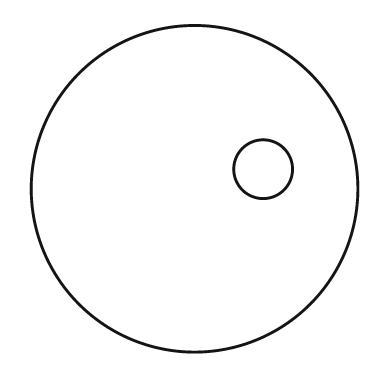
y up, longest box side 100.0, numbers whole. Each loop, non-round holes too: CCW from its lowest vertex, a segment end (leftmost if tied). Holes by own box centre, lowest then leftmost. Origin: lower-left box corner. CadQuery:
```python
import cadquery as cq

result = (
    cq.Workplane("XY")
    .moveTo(50.0, 50.0)
    .circle(50.0)
    .moveTo(71.0, 56.0)
    .circle(9.0)
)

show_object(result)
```